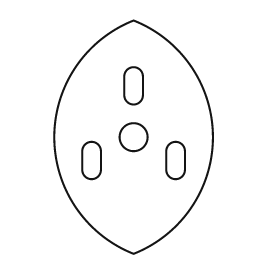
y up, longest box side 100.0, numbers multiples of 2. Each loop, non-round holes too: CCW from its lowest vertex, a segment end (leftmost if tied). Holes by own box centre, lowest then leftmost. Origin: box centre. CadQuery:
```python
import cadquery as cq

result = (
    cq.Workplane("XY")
    .moveTo(0.0, -50.0)
    .threePointArc((34.0, 0.0), (0.0, 50.0))
    .threePointArc((-34.0, 0.0), (0.0, -50.0))
    .close()
    .moveTo(-22.0, -14.0)
    .threePointArc((-18.0, -18.0), (-14.0, -14.0))
    .lineTo(-14.0, -6.0)
    .threePointArc((-18.0, -2.0), (-22.0, -6.0))
    .close()
    .moveTo(14.0, -14.0)
    .threePointArc((18.0, -18.0), (22.0, -14.0))
    .lineTo(22.0, -6.0)
    .threePointArc((18.0, -2.0), (14.0, -6.0))
    .close()
    .moveTo(0.0, 0.0)
    .circle(6.0)
    .moveTo(-4.0, 18.0)
    .threePointArc((0.0, 14.0), (4.0, 18.0))
    .lineTo(4.0, 26.0)
    .threePointArc((0.0, 30.0), (-4.0, 26.0))
    .close()
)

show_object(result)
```